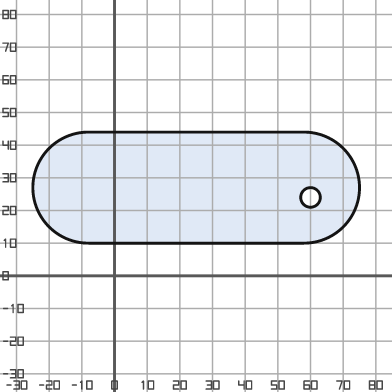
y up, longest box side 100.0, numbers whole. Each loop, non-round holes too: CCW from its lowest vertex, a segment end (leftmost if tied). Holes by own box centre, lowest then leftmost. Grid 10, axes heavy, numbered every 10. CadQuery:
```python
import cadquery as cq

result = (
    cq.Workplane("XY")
    .moveTo(-8.0, 10.0)
    .lineTo(58.0, 10.0)
    .threePointArc((75.0, 27.0), (58.0, 44.0))
    .lineTo(-8.0, 44.0)
    .threePointArc((-25.0, 27.0), (-8.0, 10.0))
    .close()
    .moveTo(60.0, 24.0)
    .circle(3.0)
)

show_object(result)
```